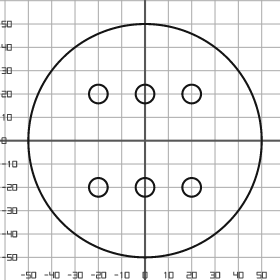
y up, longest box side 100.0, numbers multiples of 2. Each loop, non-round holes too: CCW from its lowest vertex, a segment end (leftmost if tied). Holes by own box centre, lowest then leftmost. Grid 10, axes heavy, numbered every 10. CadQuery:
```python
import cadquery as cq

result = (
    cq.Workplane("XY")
    .moveTo(0.0, 0.0)
    .circle(50.0)
    .moveTo(-20.0, -20.0)
    .circle(4.0)
    .moveTo(0.0, -20.0)
    .circle(4.0)
    .moveTo(20.0, -20.0)
    .circle(4.0)
    .moveTo(-20.0, 20.0)
    .circle(4.0)
    .moveTo(0.0, 20.0)
    .circle(4.0)
    .moveTo(20.0, 20.0)
    .circle(4.0)
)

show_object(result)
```